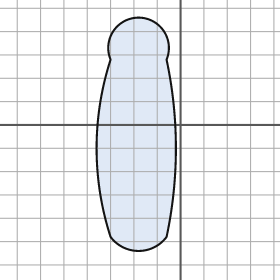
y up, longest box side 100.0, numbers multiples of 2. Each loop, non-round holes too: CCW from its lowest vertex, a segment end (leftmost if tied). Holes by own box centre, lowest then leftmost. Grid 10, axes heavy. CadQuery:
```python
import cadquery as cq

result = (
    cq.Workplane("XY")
    .moveTo(-30.0, -48.0)
    .threePointArc((-18.0, -54.0), (-6.0, -48.0))
    .threePointArc((-2.0, -10.0), (-6.0, 28.0))
    .threePointArc((-18.0, 46.0), (-30.0, 28.0))
    .threePointArc((-36.0, -10.0), (-30.0, -48.0))
    .close()
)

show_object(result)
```